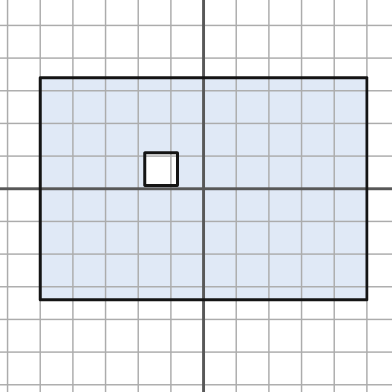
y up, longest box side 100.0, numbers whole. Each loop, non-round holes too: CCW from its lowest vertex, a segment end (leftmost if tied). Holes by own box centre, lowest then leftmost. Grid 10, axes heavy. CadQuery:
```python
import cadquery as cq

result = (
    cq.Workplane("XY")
    .moveTo(-50.0, -34.0)
    .lineTo(50.0, -34.0)
    .lineTo(50.0, 34.0)
    .lineTo(-50.0, 34.0)
    .close()
    .moveTo(-18.0, 1.0)
    .lineTo(-8.0, 1.0)
    .lineTo(-8.0, 11.0)
    .lineTo(-18.0, 11.0)
    .close()
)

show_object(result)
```